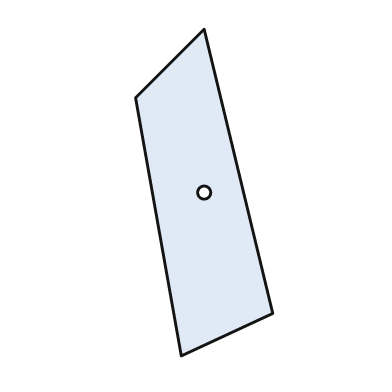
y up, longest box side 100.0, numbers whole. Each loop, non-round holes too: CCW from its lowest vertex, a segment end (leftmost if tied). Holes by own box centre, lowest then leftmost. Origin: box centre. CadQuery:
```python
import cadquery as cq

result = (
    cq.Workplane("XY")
    .moveTo(-7.0, -50.0)
    .lineTo(21.0, -37.0)
    .lineTo(0.0, 50.0)
    .lineTo(-21.0, 29.0)
    .close()
    .moveTo(0.0, 0.0)
    .circle(2.0)
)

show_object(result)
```